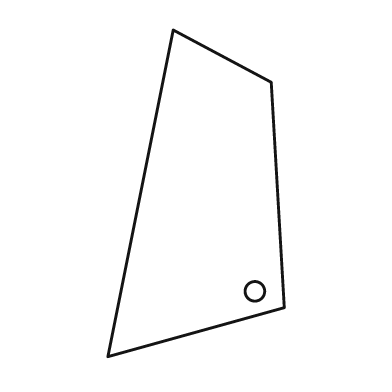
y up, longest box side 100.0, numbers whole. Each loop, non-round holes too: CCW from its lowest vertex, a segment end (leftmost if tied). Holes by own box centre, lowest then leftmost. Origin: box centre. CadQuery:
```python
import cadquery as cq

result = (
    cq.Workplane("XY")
    .moveTo(-27.0, -50.0)
    .lineTo(27.0, -35.0)
    .lineTo(23.0, 34.0)
    .lineTo(-7.0, 50.0)
    .close()
    .moveTo(18.0, -30.0)
    .circle(3.0)
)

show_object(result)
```